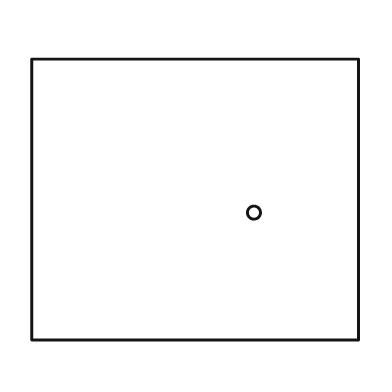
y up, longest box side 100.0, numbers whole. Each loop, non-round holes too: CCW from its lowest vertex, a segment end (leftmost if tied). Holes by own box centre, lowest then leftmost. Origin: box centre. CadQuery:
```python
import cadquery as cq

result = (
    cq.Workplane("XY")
    .moveTo(-50.0, -43.0)
    .lineTo(50.0, -43.0)
    .lineTo(50.0, 43.0)
    .lineTo(-50.0, 43.0)
    .close()
    .moveTo(18.0, -4.0)
    .circle(2.0)
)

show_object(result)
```